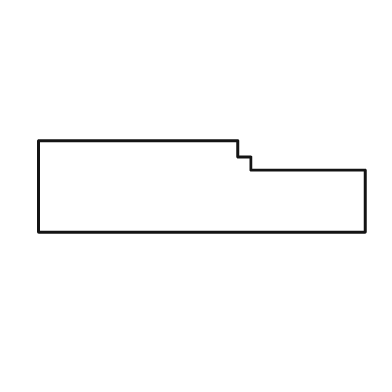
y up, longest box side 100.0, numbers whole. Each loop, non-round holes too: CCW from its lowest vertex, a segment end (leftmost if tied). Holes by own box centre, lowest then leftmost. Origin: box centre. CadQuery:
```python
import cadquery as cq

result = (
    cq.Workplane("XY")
    .moveTo(-50.0, -14.0)
    .lineTo(50.0, -14.0)
    .lineTo(50.0, 5.0)
    .lineTo(15.0, 5.0)
    .lineTo(15.0, 9.0)
    .lineTo(11.0, 9.0)
    .lineTo(11.0, 14.0)
    .lineTo(-50.0, 14.0)
    .close()
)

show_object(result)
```